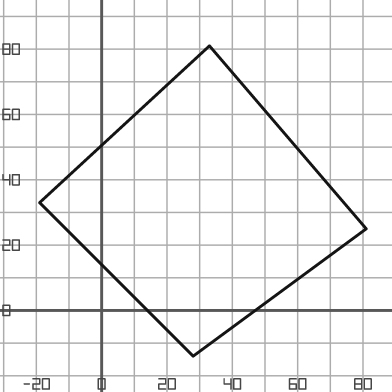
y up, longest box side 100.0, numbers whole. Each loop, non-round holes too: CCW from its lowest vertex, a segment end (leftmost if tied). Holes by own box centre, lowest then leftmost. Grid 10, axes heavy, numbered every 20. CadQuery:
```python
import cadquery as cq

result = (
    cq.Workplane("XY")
    .moveTo(28.0, -14.0)
    .lineTo(81.0, 25.0)
    .lineTo(33.0, 81.0)
    .lineTo(-19.0, 33.0)
    .close()
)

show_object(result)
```